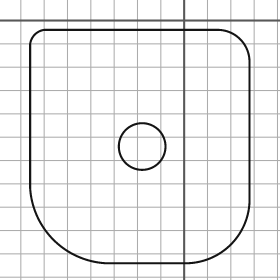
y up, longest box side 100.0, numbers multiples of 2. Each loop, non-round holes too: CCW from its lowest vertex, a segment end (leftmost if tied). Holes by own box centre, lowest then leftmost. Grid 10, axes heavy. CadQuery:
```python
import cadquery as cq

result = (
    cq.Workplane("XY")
    .moveTo(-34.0, -104.0)
    .lineTo(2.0, -104.0)
    .threePointArc((20.0, -96.0), (28.0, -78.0))
    .lineTo(28.0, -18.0)
    .threePointArc((24.0, -8.0), (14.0, -4.0))
    .lineTo(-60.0, -4.0)
    .threePointArc((-64.0, -6.0), (-66.0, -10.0))
    .lineTo(-66.0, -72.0)
    .threePointArc((-56.0, -94.0), (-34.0, -104.0))
    .close()
    .moveTo(-18.0, -54.0)
    .circle(10.0)
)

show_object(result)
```